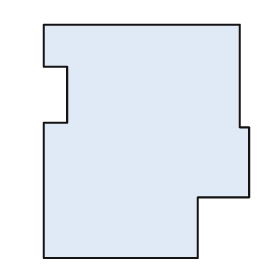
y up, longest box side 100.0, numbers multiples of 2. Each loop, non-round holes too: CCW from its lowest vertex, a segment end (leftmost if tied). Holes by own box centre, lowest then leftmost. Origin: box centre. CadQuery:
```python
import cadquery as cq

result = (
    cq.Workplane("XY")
    .moveTo(-44.0, -50.0)
    .lineTo(22.0, -50.0)
    .lineTo(22.0, -24.0)
    .lineTo(44.0, -24.0)
    .lineTo(44.0, 6.0)
    .lineTo(40.0, 6.0)
    .lineTo(40.0, 50.0)
    .lineTo(-44.0, 50.0)
    .lineTo(-44.0, 32.0)
    .lineTo(-34.0, 32.0)
    .lineTo(-34.0, 8.0)
    .lineTo(-44.0, 8.0)
    .close()
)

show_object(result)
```